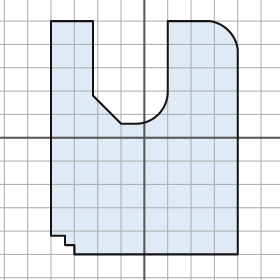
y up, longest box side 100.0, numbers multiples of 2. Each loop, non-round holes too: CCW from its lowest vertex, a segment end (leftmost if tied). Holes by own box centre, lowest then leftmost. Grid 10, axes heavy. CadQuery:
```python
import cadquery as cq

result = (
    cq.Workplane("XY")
    .moveTo(-30.0, -50.0)
    .lineTo(40.0, -50.0)
    .lineTo(40.0, 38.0)
    .threePointArc((36.0, 46.0), (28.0, 50.0))
    .lineTo(10.0, 50.0)
    .lineTo(10.0, 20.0)
    .threePointArc((6.0, 10.0), (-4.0, 6.0))
    .lineTo(-10.0, 6.0)
    .lineTo(-22.0, 18.0)
    .lineTo(-22.0, 50.0)
    .lineTo(-40.0, 50.0)
    .lineTo(-40.0, -42.0)
    .lineTo(-34.0, -42.0)
    .lineTo(-34.0, -46.0)
    .lineTo(-30.0, -46.0)
    .close()
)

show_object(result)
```